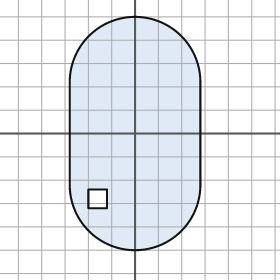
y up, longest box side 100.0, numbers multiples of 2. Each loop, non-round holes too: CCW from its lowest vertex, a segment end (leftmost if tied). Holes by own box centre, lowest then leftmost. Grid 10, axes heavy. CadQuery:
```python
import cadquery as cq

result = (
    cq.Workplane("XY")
    .moveTo(-28.0, -22.0)
    .threePointArc((0.0, -50.0), (28.0, -22.0))
    .lineTo(28.0, 22.0)
    .threePointArc((0.0, 50.0), (-28.0, 22.0))
    .close()
    .moveTo(-20.0, -32.0)
    .lineTo(-12.0, -32.0)
    .lineTo(-12.0, -24.0)
    .lineTo(-20.0, -24.0)
    .close()
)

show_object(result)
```